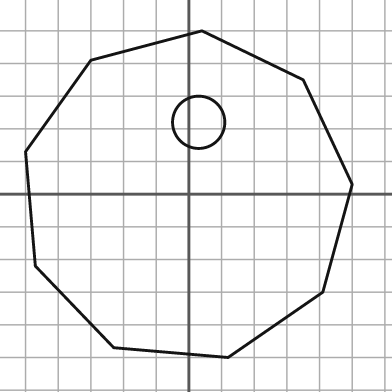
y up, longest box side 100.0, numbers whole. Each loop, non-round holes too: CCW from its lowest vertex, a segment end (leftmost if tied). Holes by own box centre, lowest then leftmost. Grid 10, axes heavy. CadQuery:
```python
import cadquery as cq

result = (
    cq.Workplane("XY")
    .moveTo(12.0, -50.0)
    .lineTo(41.0, -30.0)
    .lineTo(50.0, 3.0)
    .lineTo(35.0, 35.0)
    .lineTo(4.0, 50.0)
    .lineTo(-30.0, 41.0)
    .lineTo(-50.0, 13.0)
    .lineTo(-47.0, -22.0)
    .lineTo(-23.0, -47.0)
    .close()
    .moveTo(3.0, 22.0)
    .circle(8.0)
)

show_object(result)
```